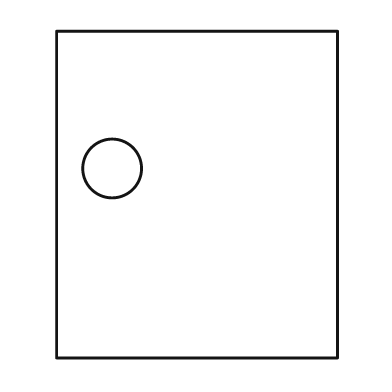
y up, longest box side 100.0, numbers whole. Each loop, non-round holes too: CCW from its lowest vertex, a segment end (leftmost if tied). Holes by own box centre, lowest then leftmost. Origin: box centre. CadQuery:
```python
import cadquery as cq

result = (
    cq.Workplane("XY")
    .moveTo(-43.0, -50.0)
    .lineTo(43.0, -50.0)
    .lineTo(43.0, 50.0)
    .lineTo(-43.0, 50.0)
    .close()
    .moveTo(-26.0, 8.0)
    .circle(9.0)
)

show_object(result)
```